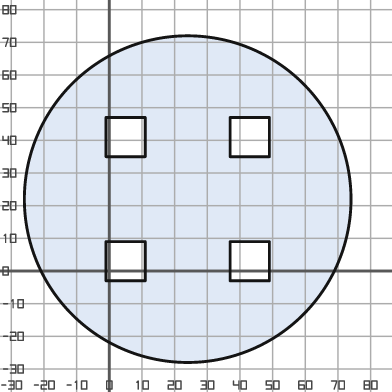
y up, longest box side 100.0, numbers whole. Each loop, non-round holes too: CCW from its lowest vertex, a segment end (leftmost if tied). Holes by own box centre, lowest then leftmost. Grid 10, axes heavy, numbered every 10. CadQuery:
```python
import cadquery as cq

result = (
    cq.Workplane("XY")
    .moveTo(24.0, 22.0)
    .circle(50.0)
    .moveTo(-1.0, -3.0)
    .lineTo(11.0, -3.0)
    .lineTo(11.0, 9.0)
    .lineTo(-1.0, 9.0)
    .close()
    .moveTo(37.0, -3.0)
    .lineTo(49.0, -3.0)
    .lineTo(49.0, 9.0)
    .lineTo(37.0, 9.0)
    .close()
    .moveTo(-1.0, 35.0)
    .lineTo(11.0, 35.0)
    .lineTo(11.0, 47.0)
    .lineTo(-1.0, 47.0)
    .close()
    .moveTo(37.0, 35.0)
    .lineTo(49.0, 35.0)
    .lineTo(49.0, 47.0)
    .lineTo(37.0, 47.0)
    .close()
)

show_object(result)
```